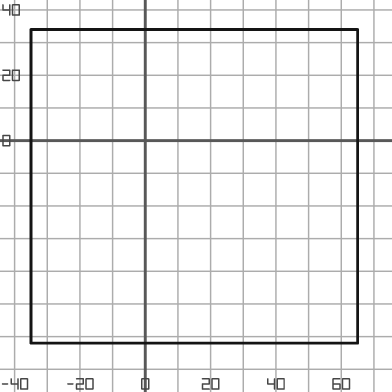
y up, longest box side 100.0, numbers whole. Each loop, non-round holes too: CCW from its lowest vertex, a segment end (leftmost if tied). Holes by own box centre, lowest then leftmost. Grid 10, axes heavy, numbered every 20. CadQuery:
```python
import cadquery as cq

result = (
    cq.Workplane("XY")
    .moveTo(-35.0, -62.0)
    .lineTo(65.0, -62.0)
    .lineTo(65.0, 34.0)
    .lineTo(-35.0, 34.0)
    .close()
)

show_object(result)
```